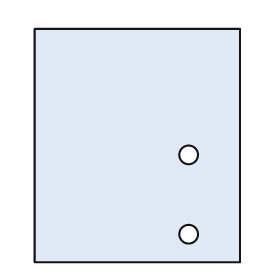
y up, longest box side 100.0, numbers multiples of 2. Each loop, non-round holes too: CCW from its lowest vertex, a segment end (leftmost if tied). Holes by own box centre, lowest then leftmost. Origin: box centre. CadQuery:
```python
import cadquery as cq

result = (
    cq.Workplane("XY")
    .moveTo(-44.0, -50.0)
    .lineTo(44.0, -50.0)
    .lineTo(44.0, 50.0)
    .lineTo(-44.0, 50.0)
    .close()
    .moveTo(22.0, -38.0)
    .circle(4.0)
    .moveTo(22.0, -4.0)
    .circle(4.0)
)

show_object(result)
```